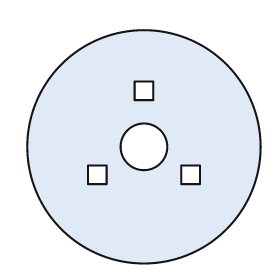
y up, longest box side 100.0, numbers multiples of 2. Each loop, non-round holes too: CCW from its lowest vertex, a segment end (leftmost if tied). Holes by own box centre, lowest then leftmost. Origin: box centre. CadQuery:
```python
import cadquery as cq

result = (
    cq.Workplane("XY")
    .moveTo(0.0, 0.0)
    .circle(50.0)
    .moveTo(-24.0, -16.0)
    .lineTo(-16.0, -16.0)
    .lineTo(-16.0, -8.0)
    .lineTo(-24.0, -8.0)
    .close()
    .moveTo(16.0, -16.0)
    .lineTo(24.0, -16.0)
    .lineTo(24.0, -8.0)
    .lineTo(16.0, -8.0)
    .close()
    .moveTo(0.0, 0.0)
    .circle(10.0)
    .moveTo(-4.0, 20.0)
    .lineTo(4.0, 20.0)
    .lineTo(4.0, 28.0)
    .lineTo(-4.0, 28.0)
    .close()
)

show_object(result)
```